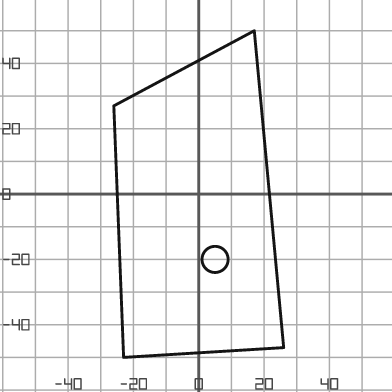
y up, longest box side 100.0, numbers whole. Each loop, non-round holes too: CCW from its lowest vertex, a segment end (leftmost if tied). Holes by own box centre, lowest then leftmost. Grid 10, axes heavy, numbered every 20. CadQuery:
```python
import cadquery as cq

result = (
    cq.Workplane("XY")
    .moveTo(-23.0, -50.0)
    .lineTo(26.0, -47.0)
    .lineTo(17.0, 50.0)
    .lineTo(-26.0, 27.0)
    .close()
    .moveTo(5.0, -20.0)
    .circle(4.0)
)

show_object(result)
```